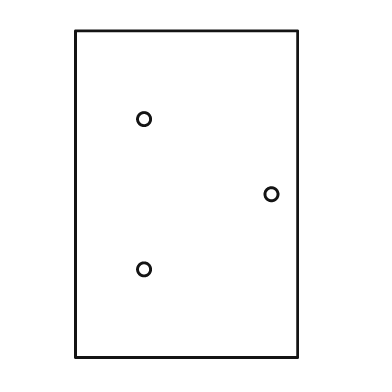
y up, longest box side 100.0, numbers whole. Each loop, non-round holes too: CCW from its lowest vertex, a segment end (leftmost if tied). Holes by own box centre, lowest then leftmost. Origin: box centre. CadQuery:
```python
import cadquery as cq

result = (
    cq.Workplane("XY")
    .moveTo(-34.0, -50.0)
    .lineTo(34.0, -50.0)
    .lineTo(34.0, 50.0)
    .lineTo(-34.0, 50.0)
    .close()
    .moveTo(-13.0, -23.0)
    .circle(2.0)
    .moveTo(26.0, 0.0)
    .circle(2.0)
    .moveTo(-13.0, 23.0)
    .circle(2.0)
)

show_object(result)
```